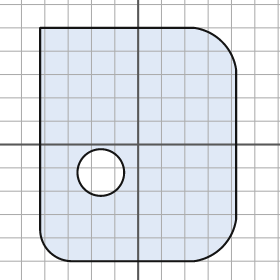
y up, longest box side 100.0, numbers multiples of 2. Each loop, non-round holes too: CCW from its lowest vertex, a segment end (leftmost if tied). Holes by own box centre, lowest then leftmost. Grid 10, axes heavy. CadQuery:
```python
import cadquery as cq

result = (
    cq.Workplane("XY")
    .moveTo(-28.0, -50.0)
    .lineTo(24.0, -50.0)
    .threePointArc((36.0, -44.0), (42.0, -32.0))
    .lineTo(42.0, 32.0)
    .threePointArc((36.0, 44.0), (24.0, 50.0))
    .lineTo(-42.0, 50.0)
    .lineTo(-42.0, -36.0)
    .threePointArc((-38.0, -46.0), (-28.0, -50.0))
    .close()
    .moveTo(-16.0, -12.0)
    .circle(10.0)
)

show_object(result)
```